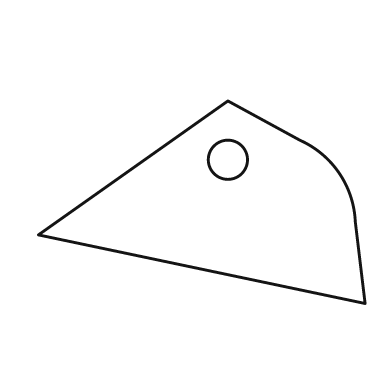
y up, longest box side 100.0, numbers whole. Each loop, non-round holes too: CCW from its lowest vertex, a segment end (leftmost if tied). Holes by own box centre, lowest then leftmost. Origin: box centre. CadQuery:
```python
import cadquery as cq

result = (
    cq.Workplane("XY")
    .moveTo(50.0, -31.0)
    .lineTo(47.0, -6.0)
    .threePointArc((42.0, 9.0), (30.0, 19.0))
    .lineTo(8.0, 31.0)
    .lineTo(-50.0, -10.0)
    .close()
    .moveTo(8.0, 13.0)
    .circle(6.0)
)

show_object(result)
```